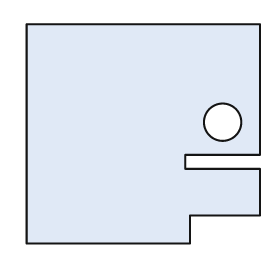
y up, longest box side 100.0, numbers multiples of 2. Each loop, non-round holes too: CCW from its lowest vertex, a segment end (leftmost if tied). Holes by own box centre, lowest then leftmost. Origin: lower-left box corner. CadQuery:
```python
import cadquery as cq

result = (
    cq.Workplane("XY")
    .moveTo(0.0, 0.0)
    .lineTo(70.0, 0.0)
    .lineTo(70.0, 12.0)
    .lineTo(100.0, 12.0)
    .lineTo(100.0, 32.0)
    .lineTo(68.0, 32.0)
    .lineTo(68.0, 38.0)
    .lineTo(100.0, 38.0)
    .lineTo(100.0, 94.0)
    .lineTo(0.0, 94.0)
    .close()
    .moveTo(84.0, 52.0)
    .circle(8.0)
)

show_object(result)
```